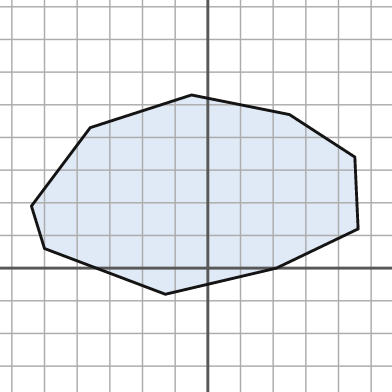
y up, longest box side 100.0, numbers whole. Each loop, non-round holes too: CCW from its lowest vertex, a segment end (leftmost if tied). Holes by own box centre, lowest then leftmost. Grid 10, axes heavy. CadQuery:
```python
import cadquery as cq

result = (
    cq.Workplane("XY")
    .moveTo(-13.0, -8.0)
    .lineTo(21.0, 0.0)
    .lineTo(46.0, 12.0)
    .lineTo(45.0, 34.0)
    .lineTo(25.0, 47.0)
    .lineTo(-5.0, 53.0)
    .lineTo(-36.0, 43.0)
    .lineTo(-54.0, 19.0)
    .lineTo(-50.0, 6.0)
    .close()
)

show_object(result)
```